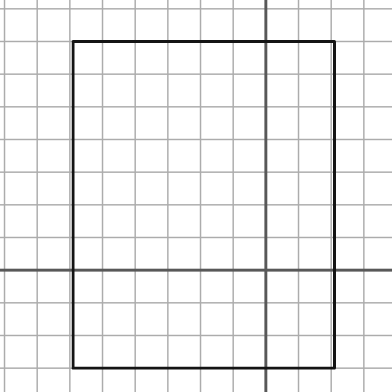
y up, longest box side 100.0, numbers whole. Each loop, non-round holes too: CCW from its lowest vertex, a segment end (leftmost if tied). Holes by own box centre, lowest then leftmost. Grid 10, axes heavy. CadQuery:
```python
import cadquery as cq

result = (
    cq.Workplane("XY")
    .moveTo(-59.0, -30.0)
    .lineTo(21.0, -30.0)
    .lineTo(21.0, 70.0)
    .lineTo(-59.0, 70.0)
    .close()
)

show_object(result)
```